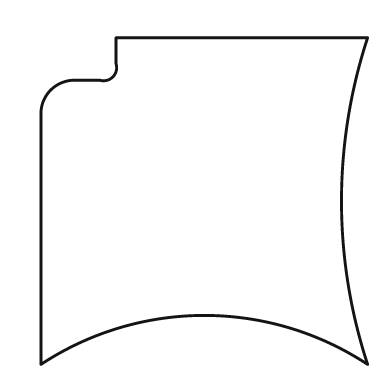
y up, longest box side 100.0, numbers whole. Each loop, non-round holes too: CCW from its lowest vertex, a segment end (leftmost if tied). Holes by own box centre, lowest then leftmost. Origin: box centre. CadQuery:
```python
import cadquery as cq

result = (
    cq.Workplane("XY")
    .moveTo(-50.0, -50.0)
    .threePointArc((0.0, -35.0), (50.0, -50.0))
    .threePointArc((42.0, 0.0), (50.0, 50.0))
    .lineTo(-27.0, 50.0)
    .lineTo(-27.0, 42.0)
    .threePointArc((-28.0, 38.0), (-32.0, 37.0))
    .lineTo(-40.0, 37.0)
    .threePointArc((-47.0, 34.0), (-50.0, 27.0))
    .close()
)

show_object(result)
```